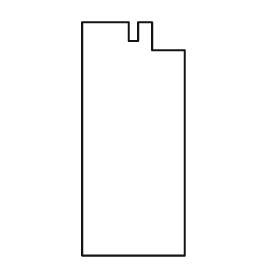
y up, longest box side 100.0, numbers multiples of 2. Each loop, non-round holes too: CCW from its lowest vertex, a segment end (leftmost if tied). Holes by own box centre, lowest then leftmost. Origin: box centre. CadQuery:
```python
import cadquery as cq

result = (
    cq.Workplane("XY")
    .moveTo(-22.0, -50.0)
    .lineTo(22.0, -50.0)
    .lineTo(22.0, 38.0)
    .lineTo(8.0, 38.0)
    .lineTo(8.0, 50.0)
    .lineTo(2.0, 50.0)
    .lineTo(2.0, 42.0)
    .lineTo(-2.0, 42.0)
    .lineTo(-2.0, 50.0)
    .lineTo(-22.0, 50.0)
    .close()
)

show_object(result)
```